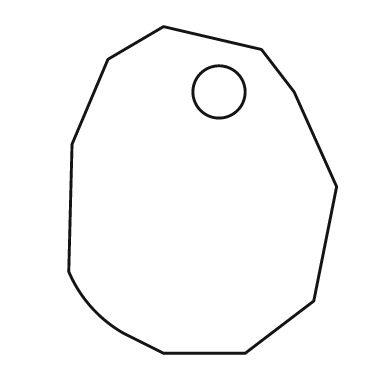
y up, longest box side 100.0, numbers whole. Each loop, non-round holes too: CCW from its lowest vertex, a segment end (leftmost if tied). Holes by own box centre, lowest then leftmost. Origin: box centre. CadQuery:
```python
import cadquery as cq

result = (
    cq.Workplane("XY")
    .moveTo(-12.0, -50.0)
    .lineTo(13.0, -50.0)
    .lineTo(34.0, -34.0)
    .lineTo(41.0, 1.0)
    .lineTo(28.0, 30.0)
    .lineTo(18.0, 43.0)
    .lineTo(-12.0, 50.0)
    .lineTo(-29.0, 40.0)
    .lineTo(-40.0, 14.0)
    .lineTo(-41.0, -25.0)
    .threePointArc((-34.0, -36.0), (-24.0, -44.0))
    .close()
    .moveTo(5.0, 30.0)
    .circle(8.0)
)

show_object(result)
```